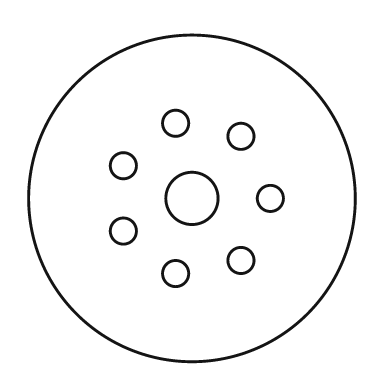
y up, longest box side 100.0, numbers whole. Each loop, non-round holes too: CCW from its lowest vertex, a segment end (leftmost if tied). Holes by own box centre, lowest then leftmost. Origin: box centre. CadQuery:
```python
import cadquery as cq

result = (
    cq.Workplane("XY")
    .moveTo(0.0, 0.0)
    .circle(50.0)
    .moveTo(-5.0, -23.0)
    .circle(4.0)
    .moveTo(15.0, -19.0)
    .circle(4.0)
    .moveTo(-21.0, -10.0)
    .circle(4.0)
    .moveTo(0.0, 0.0)
    .circle(8.0)
    .moveTo(24.0, 0.0)
    .circle(4.0)
    .moveTo(-21.0, 10.0)
    .circle(4.0)
    .moveTo(15.0, 19.0)
    .circle(4.0)
    .moveTo(-5.0, 23.0)
    .circle(4.0)
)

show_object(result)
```